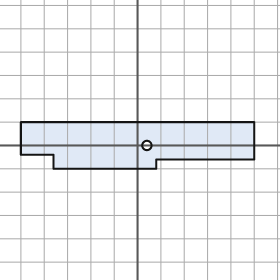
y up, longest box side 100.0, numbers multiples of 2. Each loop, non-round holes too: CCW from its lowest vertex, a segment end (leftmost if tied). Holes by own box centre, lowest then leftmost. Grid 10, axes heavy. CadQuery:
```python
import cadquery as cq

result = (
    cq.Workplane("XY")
    .moveTo(-36.0, -10.0)
    .lineTo(8.0, -10.0)
    .lineTo(8.0, -6.0)
    .lineTo(50.0, -6.0)
    .lineTo(50.0, 10.0)
    .lineTo(-50.0, 10.0)
    .lineTo(-50.0, -4.0)
    .lineTo(-36.0, -4.0)
    .close()
    .moveTo(4.0, 0.0)
    .circle(2.0)
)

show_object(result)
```